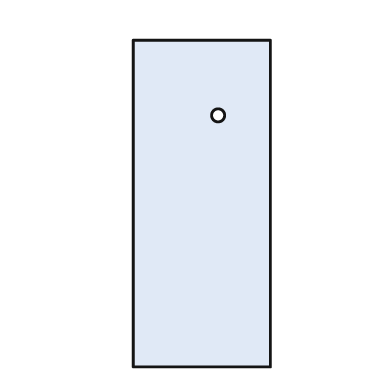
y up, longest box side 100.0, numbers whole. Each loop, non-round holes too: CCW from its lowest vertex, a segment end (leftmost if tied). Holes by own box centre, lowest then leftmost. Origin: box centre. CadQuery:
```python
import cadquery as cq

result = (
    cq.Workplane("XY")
    .moveTo(-21.0, -50.0)
    .lineTo(21.0, -50.0)
    .lineTo(21.0, 50.0)
    .lineTo(-21.0, 50.0)
    .close()
    .moveTo(5.0, 27.0)
    .circle(2.0)
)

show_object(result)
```